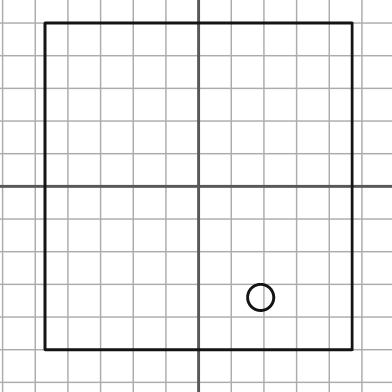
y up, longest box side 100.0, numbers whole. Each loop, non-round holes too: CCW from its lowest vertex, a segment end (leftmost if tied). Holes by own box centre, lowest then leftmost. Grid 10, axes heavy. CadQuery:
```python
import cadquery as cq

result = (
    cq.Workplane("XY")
    .moveTo(-47.0, -50.0)
    .lineTo(47.0, -50.0)
    .lineTo(47.0, 50.0)
    .lineTo(-47.0, 50.0)
    .close()
    .moveTo(19.0, -34.0)
    .circle(4.0)
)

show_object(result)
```